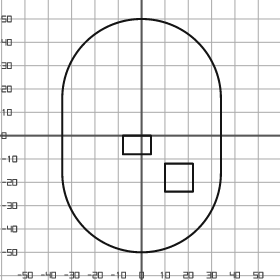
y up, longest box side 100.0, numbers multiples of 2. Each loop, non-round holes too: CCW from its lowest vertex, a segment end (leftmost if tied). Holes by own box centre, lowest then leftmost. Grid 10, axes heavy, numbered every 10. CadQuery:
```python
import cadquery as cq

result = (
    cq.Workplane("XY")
    .moveTo(-34.0, -16.0)
    .threePointArc((0.0, -50.0), (34.0, -16.0))
    .lineTo(34.0, 16.0)
    .threePointArc((0.0, 50.0), (-34.0, 16.0))
    .close()
    .moveTo(10.0, -24.0)
    .lineTo(22.0, -24.0)
    .lineTo(22.0, -12.0)
    .lineTo(10.0, -12.0)
    .close()
    .moveTo(-8.0, -8.0)
    .lineTo(4.0, -8.0)
    .lineTo(4.0, 0.0)
    .lineTo(-8.0, 0.0)
    .close()
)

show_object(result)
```